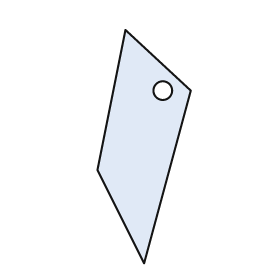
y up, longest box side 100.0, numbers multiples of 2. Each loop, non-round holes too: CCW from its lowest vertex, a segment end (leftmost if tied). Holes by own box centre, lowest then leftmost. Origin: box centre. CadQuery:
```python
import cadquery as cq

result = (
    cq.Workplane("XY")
    .moveTo(0.0, -50.0)
    .lineTo(20.0, 24.0)
    .lineTo(-8.0, 50.0)
    .lineTo(-20.0, -10.0)
    .close()
    .moveTo(8.0, 24.0)
    .circle(4.0)
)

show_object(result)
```